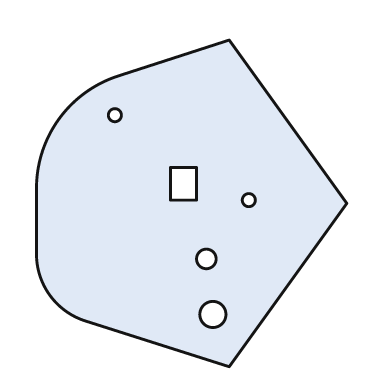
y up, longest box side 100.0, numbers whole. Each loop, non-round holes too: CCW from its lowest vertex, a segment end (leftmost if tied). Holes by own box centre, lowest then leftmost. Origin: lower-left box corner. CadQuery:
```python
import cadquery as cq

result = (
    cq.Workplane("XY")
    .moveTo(59.0, 0.0)
    .lineTo(95.0, 50.0)
    .lineTo(59.0, 100.0)
    .lineTo(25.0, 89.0)
    .threePointArc((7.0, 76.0), (0.0, 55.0))
    .lineTo(0.0, 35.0)
    .threePointArc((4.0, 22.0), (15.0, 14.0))
    .close()
    .moveTo(54.0, 16.0)
    .circle(4.0)
    .moveTo(52.0, 33.0)
    .circle(3.0)
    .moveTo(65.0, 51.0)
    .circle(2.0)
    .moveTo(41.0, 51.0)
    .lineTo(49.0, 51.0)
    .lineTo(49.0, 61.0)
    .lineTo(41.0, 61.0)
    .close()
    .moveTo(24.0, 77.0)
    .circle(2.0)
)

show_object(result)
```